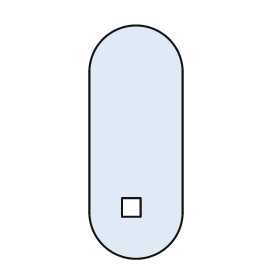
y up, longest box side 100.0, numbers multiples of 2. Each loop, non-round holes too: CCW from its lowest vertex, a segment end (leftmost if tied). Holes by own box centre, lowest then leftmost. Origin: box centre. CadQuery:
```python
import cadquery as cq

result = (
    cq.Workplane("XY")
    .moveTo(-20.0, -30.0)
    .threePointArc((0.0, -50.0), (20.0, -30.0))
    .lineTo(20.0, 30.0)
    .threePointArc((0.0, 50.0), (-20.0, 30.0))
    .close()
    .moveTo(-6.0, -32.0)
    .lineTo(2.0, -32.0)
    .lineTo(2.0, -24.0)
    .lineTo(-6.0, -24.0)
    .close()
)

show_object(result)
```